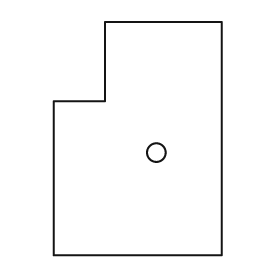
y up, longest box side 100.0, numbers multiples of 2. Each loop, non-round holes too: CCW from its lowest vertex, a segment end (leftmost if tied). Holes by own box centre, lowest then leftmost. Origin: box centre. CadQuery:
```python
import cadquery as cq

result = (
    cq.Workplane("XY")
    .moveTo(-36.0, -50.0)
    .lineTo(36.0, -50.0)
    .lineTo(36.0, 50.0)
    .lineTo(-14.0, 50.0)
    .lineTo(-14.0, 16.0)
    .lineTo(-36.0, 16.0)
    .close()
    .moveTo(8.0, -6.0)
    .circle(4.0)
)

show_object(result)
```